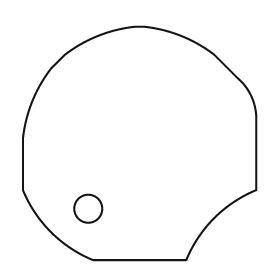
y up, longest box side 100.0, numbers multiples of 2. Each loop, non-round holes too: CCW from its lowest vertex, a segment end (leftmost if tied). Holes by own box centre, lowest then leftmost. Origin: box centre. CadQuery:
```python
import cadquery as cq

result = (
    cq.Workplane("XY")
    .moveTo(-20.0, -50.0)
    .lineTo(20.0, -50.0)
    .threePointArc((32.0, -32.0), (50.0, -20.0))
    .lineTo(50.0, 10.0)
    .threePointArc((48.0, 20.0), (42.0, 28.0))
    .lineTo(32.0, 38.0)
    .threePointArc((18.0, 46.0), (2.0, 50.0))
    .lineTo(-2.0, 50.0)
    .threePointArc((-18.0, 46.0), (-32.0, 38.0))
    .lineTo(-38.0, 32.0)
    .threePointArc((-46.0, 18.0), (-50.0, 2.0))
    .lineTo(-50.0, -20.0)
    .threePointArc((-38.0, -38.0), (-20.0, -50.0))
    .close()
    .moveTo(-22.0, -28.0)
    .circle(6.0)
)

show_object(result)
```